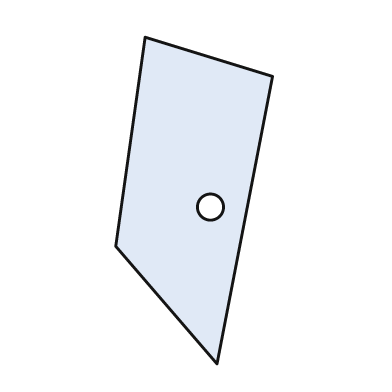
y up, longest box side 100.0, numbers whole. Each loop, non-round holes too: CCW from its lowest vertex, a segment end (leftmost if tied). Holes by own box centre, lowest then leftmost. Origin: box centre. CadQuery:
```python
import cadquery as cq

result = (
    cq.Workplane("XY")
    .moveTo(7.0, -50.0)
    .lineTo(24.0, 38.0)
    .lineTo(-15.0, 50.0)
    .lineTo(-24.0, -14.0)
    .close()
    .moveTo(5.0, -2.0)
    .circle(4.0)
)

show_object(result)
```